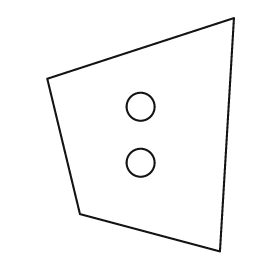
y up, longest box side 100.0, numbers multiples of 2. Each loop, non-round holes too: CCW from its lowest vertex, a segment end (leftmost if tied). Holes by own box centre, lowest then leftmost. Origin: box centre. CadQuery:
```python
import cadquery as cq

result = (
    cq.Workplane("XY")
    .moveTo(34.0, -50.0)
    .lineTo(40.0, 50.0)
    .lineTo(-40.0, 24.0)
    .lineTo(-26.0, -34.0)
    .close()
    .moveTo(0.0, -12.0)
    .circle(6.0)
    .moveTo(0.0, 12.0)
    .circle(6.0)
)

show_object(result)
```